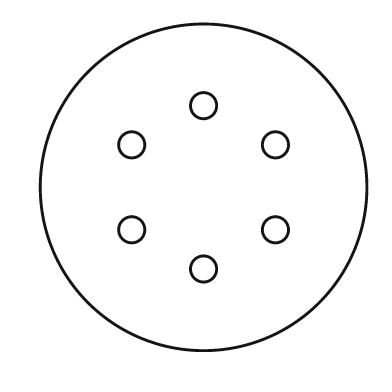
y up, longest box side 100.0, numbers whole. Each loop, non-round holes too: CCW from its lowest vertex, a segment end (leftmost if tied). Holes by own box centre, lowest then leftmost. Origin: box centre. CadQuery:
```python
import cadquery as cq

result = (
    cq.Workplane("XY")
    .moveTo(0.0, 0.0)
    .circle(50.0)
    .moveTo(0.0, -25.0)
    .circle(4.0)
    .moveTo(-22.0, -13.0)
    .circle(4.0)
    .moveTo(22.0, -13.0)
    .circle(4.0)
    .moveTo(-22.0, 13.0)
    .circle(4.0)
    .moveTo(22.0, 13.0)
    .circle(4.0)
    .moveTo(0.0, 25.0)
    .circle(4.0)
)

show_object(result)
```